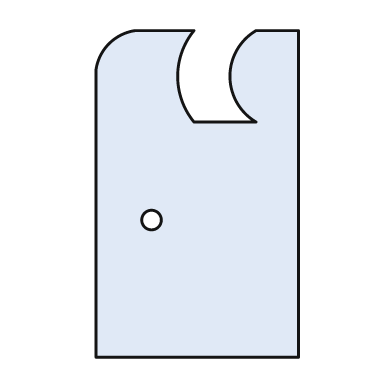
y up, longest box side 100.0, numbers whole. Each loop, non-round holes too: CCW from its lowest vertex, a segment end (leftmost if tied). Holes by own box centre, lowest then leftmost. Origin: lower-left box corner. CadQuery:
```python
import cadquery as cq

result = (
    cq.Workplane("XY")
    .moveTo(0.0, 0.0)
    .lineTo(62.0, 0.0)
    .lineTo(62.0, 100.0)
    .lineTo(49.0, 100.0)
    .threePointArc((41.0, 86.0), (49.0, 72.0))
    .lineTo(30.0, 72.0)
    .threePointArc((25.0, 86.0), (30.0, 100.0))
    .lineTo(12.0, 100.0)
    .threePointArc((4.0, 96.0), (0.0, 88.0))
    .close()
    .moveTo(17.0, 42.0)
    .circle(3.0)
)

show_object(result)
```